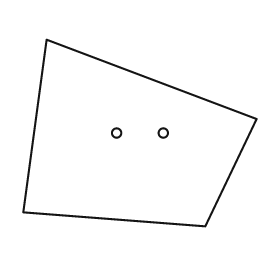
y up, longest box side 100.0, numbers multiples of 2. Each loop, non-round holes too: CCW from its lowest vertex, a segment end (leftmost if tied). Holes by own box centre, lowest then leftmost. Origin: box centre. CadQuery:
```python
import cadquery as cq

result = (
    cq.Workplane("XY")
    .moveTo(28.0, -40.0)
    .lineTo(50.0, 6.0)
    .lineTo(-40.0, 40.0)
    .lineTo(-50.0, -34.0)
    .close()
    .moveTo(-10.0, 0.0)
    .circle(2.0)
    .moveTo(10.0, 0.0)
    .circle(2.0)
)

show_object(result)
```